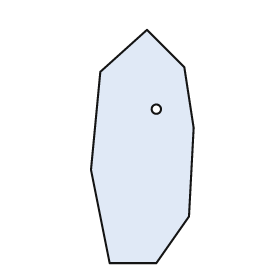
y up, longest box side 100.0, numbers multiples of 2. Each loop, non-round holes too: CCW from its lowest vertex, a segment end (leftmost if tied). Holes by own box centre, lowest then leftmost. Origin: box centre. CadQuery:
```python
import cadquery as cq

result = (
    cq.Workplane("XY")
    .moveTo(-14.0, -50.0)
    .lineTo(6.0, -50.0)
    .lineTo(20.0, -30.0)
    .lineTo(22.0, 8.0)
    .lineTo(18.0, 34.0)
    .lineTo(2.0, 50.0)
    .lineTo(-18.0, 32.0)
    .lineTo(-22.0, -10.0)
    .close()
    .moveTo(6.0, 16.0)
    .circle(2.0)
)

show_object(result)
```